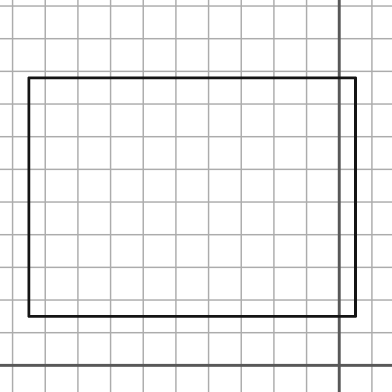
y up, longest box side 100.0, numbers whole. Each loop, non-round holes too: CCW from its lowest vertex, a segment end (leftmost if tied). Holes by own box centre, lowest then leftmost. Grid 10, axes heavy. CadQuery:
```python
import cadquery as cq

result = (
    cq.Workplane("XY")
    .moveTo(-95.0, 15.0)
    .lineTo(5.0, 15.0)
    .lineTo(5.0, 88.0)
    .lineTo(-95.0, 88.0)
    .close()
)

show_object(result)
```